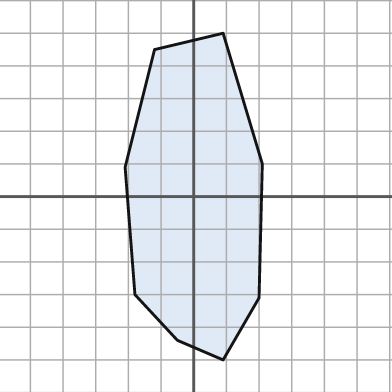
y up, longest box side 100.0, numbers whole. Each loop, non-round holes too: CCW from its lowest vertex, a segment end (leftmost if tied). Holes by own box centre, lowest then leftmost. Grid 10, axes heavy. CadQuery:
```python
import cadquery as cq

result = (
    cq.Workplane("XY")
    .moveTo(9.0, -50.0)
    .lineTo(20.0, -31.0)
    .lineTo(21.0, 10.0)
    .lineTo(9.0, 50.0)
    .lineTo(-12.0, 45.0)
    .lineTo(-21.0, 9.0)
    .lineTo(-18.0, -30.0)
    .lineTo(-5.0, -44.0)
    .close()
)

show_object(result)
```